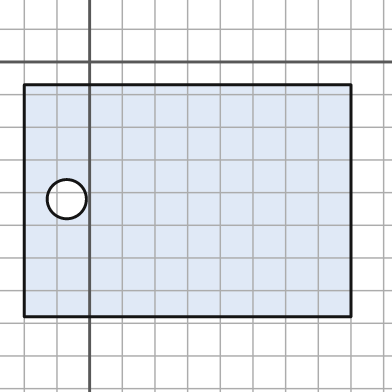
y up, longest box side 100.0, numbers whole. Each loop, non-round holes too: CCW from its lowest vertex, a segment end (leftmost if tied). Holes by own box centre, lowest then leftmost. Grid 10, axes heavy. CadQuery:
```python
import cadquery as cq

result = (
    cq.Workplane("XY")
    .moveTo(-20.0, -78.0)
    .lineTo(80.0, -78.0)
    .lineTo(80.0, -7.0)
    .lineTo(-20.0, -7.0)
    .close()
    .moveTo(-7.0, -42.0)
    .circle(6.0)
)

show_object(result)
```